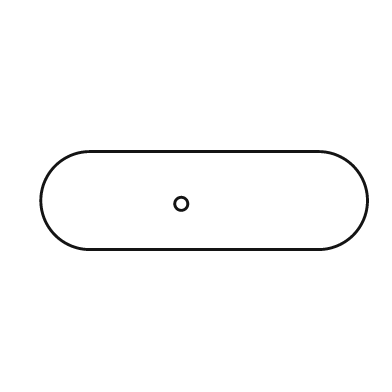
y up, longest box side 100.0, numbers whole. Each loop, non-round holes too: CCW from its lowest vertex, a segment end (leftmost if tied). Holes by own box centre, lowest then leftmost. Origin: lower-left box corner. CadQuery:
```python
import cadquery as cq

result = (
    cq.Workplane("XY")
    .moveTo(15.0, 0.0)
    .lineTo(85.0, 0.0)
    .threePointArc((100.0, 15.0), (85.0, 30.0))
    .lineTo(15.0, 30.0)
    .threePointArc((0.0, 15.0), (15.0, 0.0))
    .close()
    .moveTo(43.0, 14.0)
    .circle(2.0)
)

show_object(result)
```